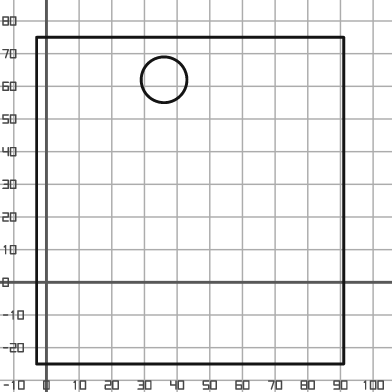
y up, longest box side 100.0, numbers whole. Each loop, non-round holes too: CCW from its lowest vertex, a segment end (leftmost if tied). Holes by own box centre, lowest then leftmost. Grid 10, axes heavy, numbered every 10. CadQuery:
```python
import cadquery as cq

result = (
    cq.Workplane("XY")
    .moveTo(-3.0, -25.0)
    .lineTo(91.0, -25.0)
    .lineTo(91.0, 75.0)
    .lineTo(-3.0, 75.0)
    .close()
    .moveTo(36.0, 62.0)
    .circle(7.0)
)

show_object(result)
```